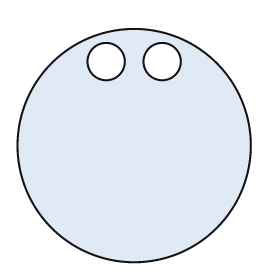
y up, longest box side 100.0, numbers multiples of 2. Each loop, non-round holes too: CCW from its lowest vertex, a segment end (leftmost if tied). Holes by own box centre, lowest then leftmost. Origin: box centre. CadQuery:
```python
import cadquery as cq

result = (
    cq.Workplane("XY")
    .moveTo(0.0, 0.0)
    .circle(50.0)
    .moveTo(-12.0, 36.0)
    .circle(8.0)
    .moveTo(12.0, 36.0)
    .circle(8.0)
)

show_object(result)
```